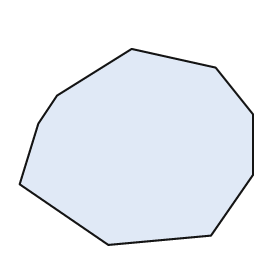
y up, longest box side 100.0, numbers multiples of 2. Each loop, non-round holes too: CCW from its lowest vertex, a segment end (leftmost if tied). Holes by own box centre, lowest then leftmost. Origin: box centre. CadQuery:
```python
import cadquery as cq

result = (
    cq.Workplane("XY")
    .moveTo(-12.0, -42.0)
    .lineTo(32.0, -38.0)
    .lineTo(50.0, -12.0)
    .lineTo(50.0, 14.0)
    .lineTo(34.0, 34.0)
    .lineTo(-2.0, 42.0)
    .lineTo(-34.0, 22.0)
    .lineTo(-42.0, 10.0)
    .lineTo(-50.0, -16.0)
    .close()
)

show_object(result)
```